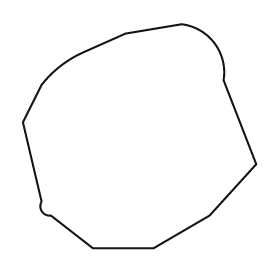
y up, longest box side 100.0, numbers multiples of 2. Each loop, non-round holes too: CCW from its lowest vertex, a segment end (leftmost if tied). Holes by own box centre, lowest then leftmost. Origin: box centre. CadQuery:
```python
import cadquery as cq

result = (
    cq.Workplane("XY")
    .moveTo(-20.0, -48.0)
    .lineTo(6.0, -48.0)
    .lineTo(30.0, -34.0)
    .lineTo(50.0, -12.0)
    .lineTo(36.0, 24.0)
    .threePointArc((32.0, 40.0), (18.0, 48.0))
    .lineTo(-6.0, 44.0)
    .lineTo(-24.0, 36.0)
    .threePointArc((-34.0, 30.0), (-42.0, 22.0))
    .lineTo(-50.0, 6.0)
    .lineTo(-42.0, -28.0)
    .threePointArc((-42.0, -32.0), (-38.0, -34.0))
    .close()
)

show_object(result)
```